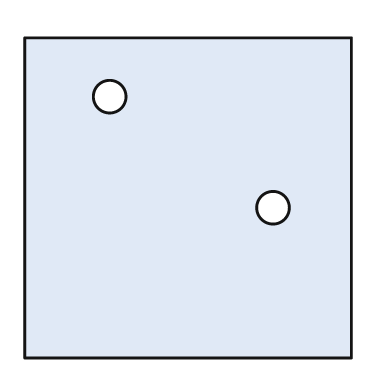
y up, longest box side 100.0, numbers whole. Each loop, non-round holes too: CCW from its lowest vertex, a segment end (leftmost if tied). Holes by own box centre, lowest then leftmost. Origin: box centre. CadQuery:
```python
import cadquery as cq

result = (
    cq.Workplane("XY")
    .moveTo(-50.0, -49.0)
    .lineTo(50.0, -49.0)
    .lineTo(50.0, 49.0)
    .lineTo(-50.0, 49.0)
    .close()
    .moveTo(26.0, -3.0)
    .circle(5.0)
    .moveTo(-24.0, 31.0)
    .circle(5.0)
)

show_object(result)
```